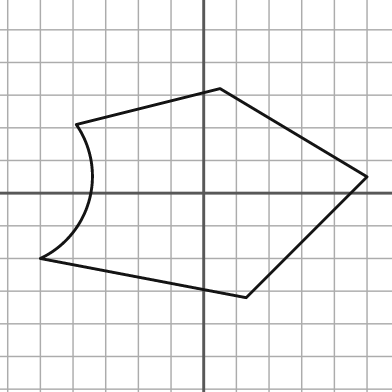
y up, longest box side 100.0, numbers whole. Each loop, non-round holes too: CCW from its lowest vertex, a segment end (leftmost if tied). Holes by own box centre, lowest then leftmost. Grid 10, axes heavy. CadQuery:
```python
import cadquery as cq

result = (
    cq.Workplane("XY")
    .moveTo(13.0, -32.0)
    .lineTo(50.0, 5.0)
    .lineTo(5.0, 32.0)
    .lineTo(-39.0, 21.0)
    .threePointArc((-35.0, -2.0), (-50.0, -20.0))
    .close()
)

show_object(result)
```